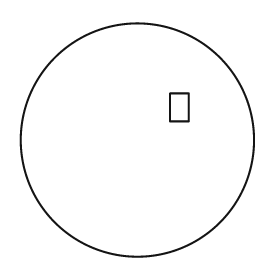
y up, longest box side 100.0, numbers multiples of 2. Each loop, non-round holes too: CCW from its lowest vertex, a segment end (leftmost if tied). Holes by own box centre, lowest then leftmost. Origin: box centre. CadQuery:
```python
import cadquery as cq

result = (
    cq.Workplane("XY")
    .moveTo(0.0, 0.0)
    .circle(50.0)
    .moveTo(14.0, 8.0)
    .lineTo(22.0, 8.0)
    .lineTo(22.0, 20.0)
    .lineTo(14.0, 20.0)
    .close()
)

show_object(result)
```